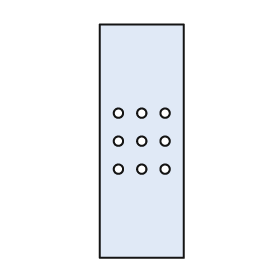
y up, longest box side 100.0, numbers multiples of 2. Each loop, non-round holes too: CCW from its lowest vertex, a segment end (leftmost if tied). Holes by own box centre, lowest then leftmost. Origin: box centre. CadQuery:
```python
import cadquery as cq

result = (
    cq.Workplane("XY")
    .moveTo(-18.0, -50.0)
    .lineTo(18.0, -50.0)
    .lineTo(18.0, 50.0)
    .lineTo(-18.0, 50.0)
    .close()
    .moveTo(-10.0, -12.0)
    .circle(2.0)
    .moveTo(0.0, -12.0)
    .circle(2.0)
    .moveTo(10.0, -12.0)
    .circle(2.0)
    .moveTo(-10.0, 0.0)
    .circle(2.0)
    .moveTo(0.0, 0.0)
    .circle(2.0)
    .moveTo(10.0, 0.0)
    .circle(2.0)
    .moveTo(-10.0, 12.0)
    .circle(2.0)
    .moveTo(0.0, 12.0)
    .circle(2.0)
    .moveTo(10.0, 12.0)
    .circle(2.0)
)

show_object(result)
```